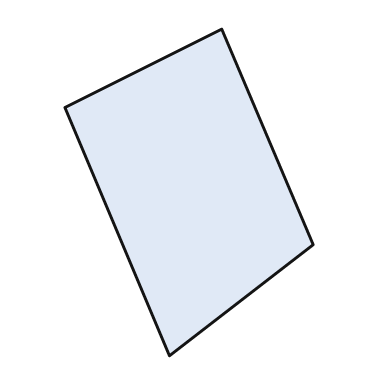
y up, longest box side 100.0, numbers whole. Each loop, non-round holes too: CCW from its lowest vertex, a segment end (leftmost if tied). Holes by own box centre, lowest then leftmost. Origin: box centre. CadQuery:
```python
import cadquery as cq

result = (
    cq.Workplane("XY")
    .moveTo(-6.0, -50.0)
    .lineTo(38.0, -16.0)
    .lineTo(10.0, 50.0)
    .lineTo(-38.0, 26.0)
    .close()
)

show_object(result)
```